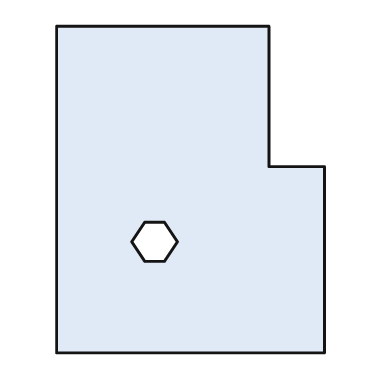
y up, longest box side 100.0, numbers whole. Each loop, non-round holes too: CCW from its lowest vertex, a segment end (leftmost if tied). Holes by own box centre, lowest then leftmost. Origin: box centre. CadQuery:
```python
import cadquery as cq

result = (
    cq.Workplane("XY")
    .moveTo(-41.0, -50.0)
    .lineTo(41.0, -50.0)
    .lineTo(41.0, 7.0)
    .lineTo(24.0, 7.0)
    .lineTo(24.0, 50.0)
    .lineTo(-41.0, 50.0)
    .close()
    .moveTo(-14.0, -22.0)
    .lineTo(-8.0, -22.0)
    .lineTo(-4.0, -16.0)
    .lineTo(-8.0, -10.0)
    .lineTo(-14.0, -10.0)
    .lineTo(-18.0, -16.0)
    .close()
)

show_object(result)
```